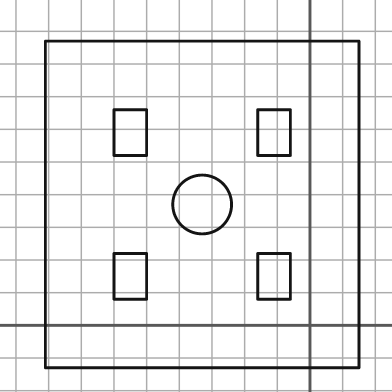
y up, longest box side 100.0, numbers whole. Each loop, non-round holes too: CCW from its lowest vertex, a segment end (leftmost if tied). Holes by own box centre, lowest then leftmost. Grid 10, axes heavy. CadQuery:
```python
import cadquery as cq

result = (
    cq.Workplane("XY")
    .moveTo(-81.0, -13.0)
    .lineTo(15.0, -13.0)
    .lineTo(15.0, 87.0)
    .lineTo(-81.0, 87.0)
    .close()
    .moveTo(-60.0, 8.0)
    .lineTo(-50.0, 8.0)
    .lineTo(-50.0, 22.0)
    .lineTo(-60.0, 22.0)
    .close()
    .moveTo(-16.0, 8.0)
    .lineTo(-6.0, 8.0)
    .lineTo(-6.0, 22.0)
    .lineTo(-16.0, 22.0)
    .close()
    .moveTo(-33.0, 37.0)
    .circle(9.0)
    .moveTo(-60.0, 52.0)
    .lineTo(-50.0, 52.0)
    .lineTo(-50.0, 66.0)
    .lineTo(-60.0, 66.0)
    .close()
    .moveTo(-16.0, 52.0)
    .lineTo(-6.0, 52.0)
    .lineTo(-6.0, 66.0)
    .lineTo(-16.0, 66.0)
    .close()
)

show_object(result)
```